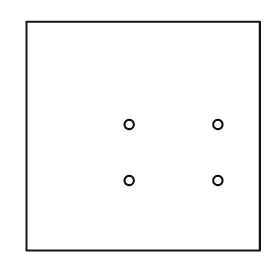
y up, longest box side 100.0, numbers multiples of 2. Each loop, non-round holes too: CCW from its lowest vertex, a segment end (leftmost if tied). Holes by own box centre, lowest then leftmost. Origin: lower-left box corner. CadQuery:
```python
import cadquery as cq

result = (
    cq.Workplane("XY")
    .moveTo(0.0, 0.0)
    .lineTo(100.0, 0.0)
    .lineTo(100.0, 98.0)
    .lineTo(0.0, 98.0)
    .close()
    .moveTo(44.0, 30.0)
    .circle(2.0)
    .moveTo(82.0, 30.0)
    .circle(2.0)
    .moveTo(44.0, 54.0)
    .circle(2.0)
    .moveTo(82.0, 54.0)
    .circle(2.0)
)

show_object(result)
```